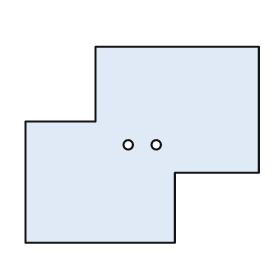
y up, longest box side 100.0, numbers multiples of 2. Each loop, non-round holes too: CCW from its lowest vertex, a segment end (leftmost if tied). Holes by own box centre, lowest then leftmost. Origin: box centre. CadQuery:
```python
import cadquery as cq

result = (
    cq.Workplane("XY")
    .moveTo(-50.0, -42.0)
    .lineTo(14.0, -42.0)
    .lineTo(14.0, -12.0)
    .lineTo(50.0, -12.0)
    .lineTo(50.0, 42.0)
    .lineTo(-20.0, 42.0)
    .lineTo(-20.0, 10.0)
    .lineTo(-50.0, 10.0)
    .close()
    .moveTo(-6.0, 0.0)
    .circle(2.0)
    .moveTo(6.0, 0.0)
    .circle(2.0)
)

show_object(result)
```